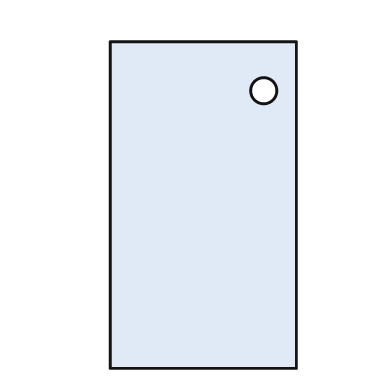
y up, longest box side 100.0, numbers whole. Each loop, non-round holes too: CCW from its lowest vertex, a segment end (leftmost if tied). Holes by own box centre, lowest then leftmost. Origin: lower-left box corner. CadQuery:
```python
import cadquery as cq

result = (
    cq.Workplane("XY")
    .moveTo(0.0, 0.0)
    .lineTo(57.0, 0.0)
    .lineTo(57.0, 100.0)
    .lineTo(0.0, 100.0)
    .close()
    .moveTo(47.0, 85.0)
    .circle(4.0)
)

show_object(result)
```